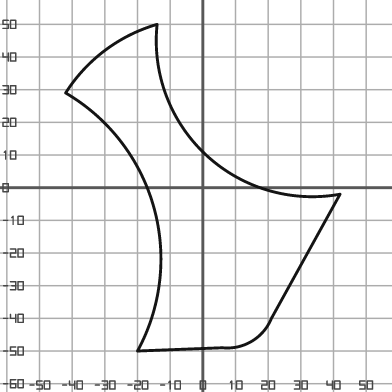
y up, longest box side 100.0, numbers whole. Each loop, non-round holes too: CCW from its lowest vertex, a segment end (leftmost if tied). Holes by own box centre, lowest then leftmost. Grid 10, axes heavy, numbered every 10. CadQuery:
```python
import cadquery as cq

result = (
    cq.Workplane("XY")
    .moveTo(-20.0, -50.0)
    .lineTo(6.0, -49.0)
    .threePointArc((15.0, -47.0), (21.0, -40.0))
    .lineTo(42.0, -2.0)
    .threePointArc((1.0, 10.0), (-14.0, 50.0))
    .threePointArc((-30.0, 42.0), (-42.0, 29.0))
    .threePointArc((-15.0, -6.0), (-20.0, -50.0))
    .close()
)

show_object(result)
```